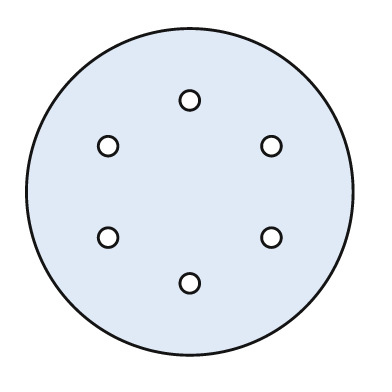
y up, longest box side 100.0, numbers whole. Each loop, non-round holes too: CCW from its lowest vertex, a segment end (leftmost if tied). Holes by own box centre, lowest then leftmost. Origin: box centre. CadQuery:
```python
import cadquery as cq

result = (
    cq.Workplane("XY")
    .moveTo(0.0, 0.0)
    .circle(50.0)
    .moveTo(0.0, -28.0)
    .circle(3.0)
    .moveTo(-25.0, -14.0)
    .circle(3.0)
    .moveTo(25.0, -14.0)
    .circle(3.0)
    .moveTo(-25.0, 14.0)
    .circle(3.0)
    .moveTo(25.0, 14.0)
    .circle(3.0)
    .moveTo(0.0, 28.0)
    .circle(3.0)
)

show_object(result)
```